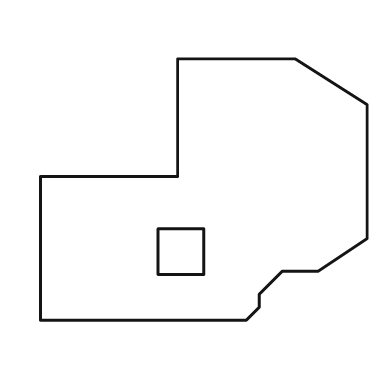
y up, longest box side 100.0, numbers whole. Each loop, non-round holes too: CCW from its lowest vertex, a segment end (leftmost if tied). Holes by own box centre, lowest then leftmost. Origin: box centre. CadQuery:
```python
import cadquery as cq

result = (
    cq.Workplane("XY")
    .moveTo(-50.0, -40.0)
    .lineTo(13.0, -40.0)
    .lineTo(17.0, -36.0)
    .lineTo(17.0, -32.0)
    .lineTo(24.0, -25.0)
    .lineTo(35.0, -25.0)
    .lineTo(50.0, -15.0)
    .lineTo(50.0, 26.0)
    .lineTo(28.0, 40.0)
    .lineTo(-8.0, 40.0)
    .lineTo(-8.0, 4.0)
    .lineTo(-50.0, 4.0)
    .close()
    .moveTo(-14.0, -26.0)
    .lineTo(0.0, -26.0)
    .lineTo(0.0, -12.0)
    .lineTo(-14.0, -12.0)
    .close()
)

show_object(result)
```